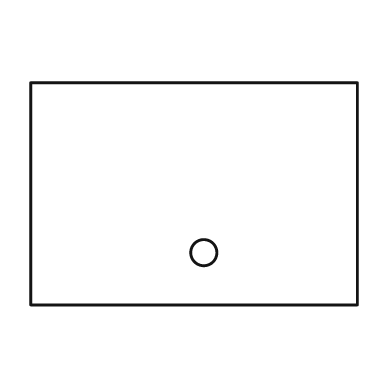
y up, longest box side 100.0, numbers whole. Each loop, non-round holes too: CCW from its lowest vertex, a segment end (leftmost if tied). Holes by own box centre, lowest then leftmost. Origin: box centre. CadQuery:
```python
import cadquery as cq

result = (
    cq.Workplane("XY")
    .moveTo(-50.0, -34.0)
    .lineTo(50.0, -34.0)
    .lineTo(50.0, 34.0)
    .lineTo(-50.0, 34.0)
    .close()
    .moveTo(3.0, -18.0)
    .circle(4.0)
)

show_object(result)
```